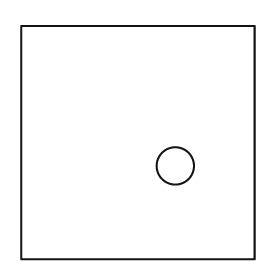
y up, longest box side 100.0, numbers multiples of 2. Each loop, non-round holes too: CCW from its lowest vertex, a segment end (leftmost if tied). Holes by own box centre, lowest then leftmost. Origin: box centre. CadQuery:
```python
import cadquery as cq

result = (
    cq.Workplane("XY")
    .moveTo(-50.0, -50.0)
    .lineTo(50.0, -50.0)
    .lineTo(50.0, 50.0)
    .lineTo(-50.0, 50.0)
    .close()
    .moveTo(16.0, -10.0)
    .circle(8.0)
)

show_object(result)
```